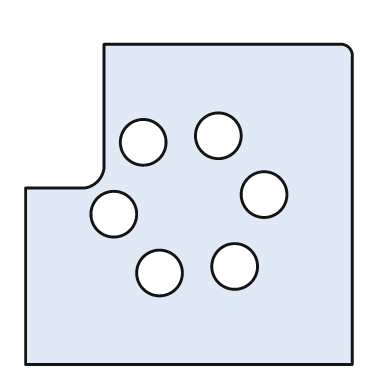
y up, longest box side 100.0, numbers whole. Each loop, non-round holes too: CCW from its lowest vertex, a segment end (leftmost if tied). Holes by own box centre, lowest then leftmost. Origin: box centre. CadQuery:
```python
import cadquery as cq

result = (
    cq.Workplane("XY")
    .moveTo(-50.0, -49.0)
    .lineTo(50.0, -49.0)
    .lineTo(50.0, 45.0)
    .threePointArc((49.0, 48.0), (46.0, 49.0))
    .lineTo(-26.0, 49.0)
    .lineTo(-26.0, 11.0)
    .threePointArc((-28.0, 7.0), (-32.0, 5.0))
    .lineTo(-50.0, 5.0)
    .close()
    .moveTo(-9.0, -21.0)
    .circle(7.0)
    .moveTo(14.0, -19.0)
    .circle(7.0)
    .moveTo(-23.0, -3.0)
    .circle(7.0)
    .moveTo(23.0, 3.0)
    .circle(7.0)
    .moveTo(-14.0, 19.0)
    .circle(7.0)
    .moveTo(9.0, 21.0)
    .circle(7.0)
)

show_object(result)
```